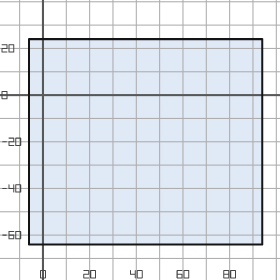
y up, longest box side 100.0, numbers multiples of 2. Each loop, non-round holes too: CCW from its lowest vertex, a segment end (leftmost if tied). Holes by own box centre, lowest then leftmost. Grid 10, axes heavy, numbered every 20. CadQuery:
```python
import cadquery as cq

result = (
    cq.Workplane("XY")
    .moveTo(-6.0, -64.0)
    .lineTo(94.0, -64.0)
    .lineTo(94.0, 24.0)
    .lineTo(-6.0, 24.0)
    .close()
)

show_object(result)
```